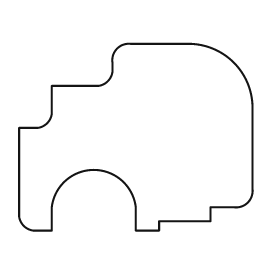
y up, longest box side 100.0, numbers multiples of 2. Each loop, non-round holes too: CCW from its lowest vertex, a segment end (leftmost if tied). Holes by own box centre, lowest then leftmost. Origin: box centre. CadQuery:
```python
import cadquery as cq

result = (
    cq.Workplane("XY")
    .moveTo(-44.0, -40.0)
    .lineTo(-36.0, -40.0)
    .lineTo(-36.0, -30.0)
    .threePointArc((-18.0, -14.0), (0.0, -30.0))
    .lineTo(0.0, -40.0)
    .lineTo(10.0, -40.0)
    .lineTo(10.0, -36.0)
    .lineTo(32.0, -36.0)
    .lineTo(32.0, -30.0)
    .lineTo(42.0, -30.0)
    .threePointArc((48.0, -28.0), (50.0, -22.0))
    .lineTo(50.0, 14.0)
    .threePointArc((42.0, 32.0), (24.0, 40.0))
    .lineTo(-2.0, 40.0)
    .threePointArc((-8.0, 38.0), (-10.0, 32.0))
    .lineTo(-10.0, 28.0)
    .threePointArc((-12.0, 24.0), (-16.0, 22.0))
    .lineTo(-36.0, 22.0)
    .lineTo(-36.0, 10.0)
    .threePointArc((-38.0, 6.0), (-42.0, 4.0))
    .lineTo(-50.0, 4.0)
    .lineTo(-50.0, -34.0)
    .threePointArc((-48.0, -38.0), (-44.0, -40.0))
    .close()
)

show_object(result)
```